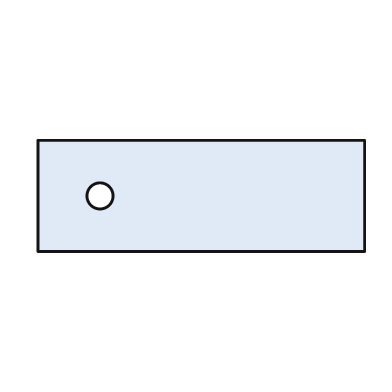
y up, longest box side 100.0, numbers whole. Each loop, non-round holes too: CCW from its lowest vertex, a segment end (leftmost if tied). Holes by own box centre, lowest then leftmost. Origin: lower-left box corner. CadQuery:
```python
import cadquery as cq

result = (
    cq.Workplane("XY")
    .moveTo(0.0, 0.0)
    .lineTo(100.0, 0.0)
    .lineTo(100.0, 34.0)
    .lineTo(0.0, 34.0)
    .close()
    .moveTo(19.0, 17.0)
    .circle(4.0)
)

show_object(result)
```